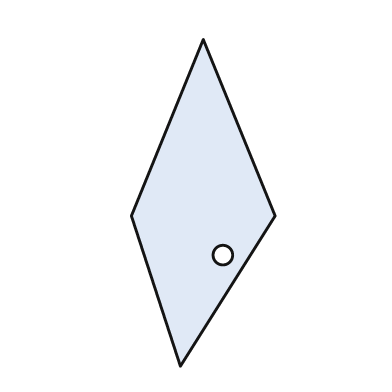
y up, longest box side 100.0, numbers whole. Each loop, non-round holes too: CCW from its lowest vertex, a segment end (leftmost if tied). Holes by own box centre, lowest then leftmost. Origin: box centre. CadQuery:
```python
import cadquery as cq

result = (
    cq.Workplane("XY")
    .moveTo(-7.0, -50.0)
    .lineTo(22.0, -4.0)
    .lineTo(0.0, 50.0)
    .lineTo(-22.0, -4.0)
    .close()
    .moveTo(6.0, -16.0)
    .circle(3.0)
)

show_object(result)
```